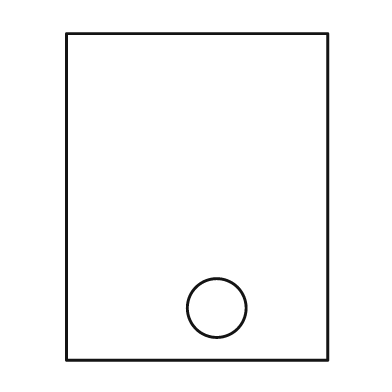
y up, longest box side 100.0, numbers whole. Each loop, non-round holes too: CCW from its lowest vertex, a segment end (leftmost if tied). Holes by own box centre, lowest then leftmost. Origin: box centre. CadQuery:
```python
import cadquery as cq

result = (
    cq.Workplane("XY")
    .moveTo(-40.0, -50.0)
    .lineTo(40.0, -50.0)
    .lineTo(40.0, 50.0)
    .lineTo(-40.0, 50.0)
    .close()
    .moveTo(6.0, -34.0)
    .circle(9.0)
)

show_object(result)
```